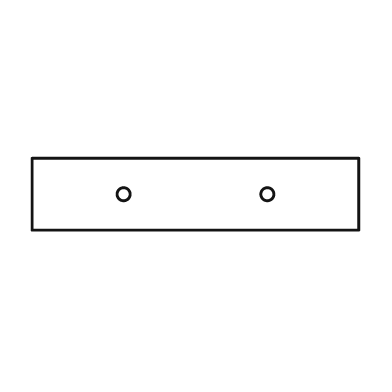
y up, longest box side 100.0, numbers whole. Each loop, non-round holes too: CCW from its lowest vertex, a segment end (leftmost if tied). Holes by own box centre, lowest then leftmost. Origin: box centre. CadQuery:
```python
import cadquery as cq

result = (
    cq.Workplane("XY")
    .moveTo(-50.0, -11.0)
    .lineTo(50.0, -11.0)
    .lineTo(50.0, 11.0)
    .lineTo(-50.0, 11.0)
    .close()
    .moveTo(-22.0, 0.0)
    .circle(2.0)
    .moveTo(22.0, 0.0)
    .circle(2.0)
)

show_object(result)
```